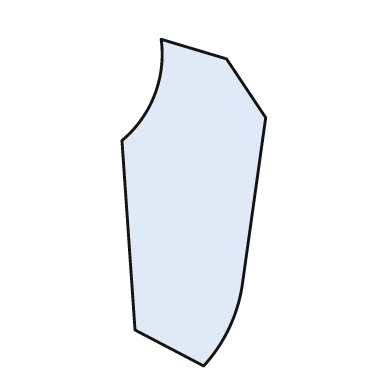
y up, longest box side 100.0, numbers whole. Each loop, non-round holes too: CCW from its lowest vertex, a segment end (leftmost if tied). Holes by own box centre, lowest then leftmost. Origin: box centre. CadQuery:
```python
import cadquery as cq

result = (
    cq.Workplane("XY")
    .moveTo(3.0, -50.0)
    .threePointArc((11.0, -38.0), (15.0, -24.0))
    .lineTo(22.0, 26.0)
    .lineTo(10.0, 44.0)
    .lineTo(-10.0, 50.0)
    .threePointArc((-12.0, 33.0), (-22.0, 19.0))
    .lineTo(-18.0, -39.0)
    .close()
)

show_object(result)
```